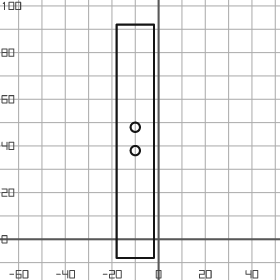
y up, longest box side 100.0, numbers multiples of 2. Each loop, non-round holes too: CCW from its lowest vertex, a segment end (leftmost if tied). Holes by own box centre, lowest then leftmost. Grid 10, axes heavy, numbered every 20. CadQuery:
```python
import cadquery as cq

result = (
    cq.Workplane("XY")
    .moveTo(-18.0, -8.0)
    .lineTo(-2.0, -8.0)
    .lineTo(-2.0, 92.0)
    .lineTo(-18.0, 92.0)
    .close()
    .moveTo(-10.0, 38.0)
    .circle(2.0)
    .moveTo(-10.0, 48.0)
    .circle(2.0)
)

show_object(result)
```